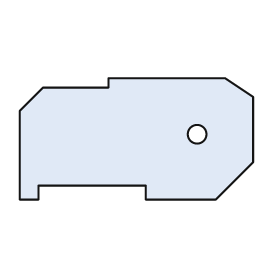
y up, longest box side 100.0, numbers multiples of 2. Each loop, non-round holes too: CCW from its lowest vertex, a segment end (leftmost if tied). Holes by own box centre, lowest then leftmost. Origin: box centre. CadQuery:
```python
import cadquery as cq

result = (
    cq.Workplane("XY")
    .moveTo(-50.0, -26.0)
    .lineTo(-42.0, -26.0)
    .lineTo(-42.0, -20.0)
    .lineTo(4.0, -20.0)
    .lineTo(4.0, -26.0)
    .lineTo(34.0, -26.0)
    .lineTo(50.0, -10.0)
    .lineTo(50.0, 18.0)
    .lineTo(38.0, 26.0)
    .lineTo(-12.0, 26.0)
    .lineTo(-12.0, 22.0)
    .lineTo(-40.0, 22.0)
    .lineTo(-50.0, 12.0)
    .close()
    .moveTo(26.0, 2.0)
    .circle(4.0)
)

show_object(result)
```